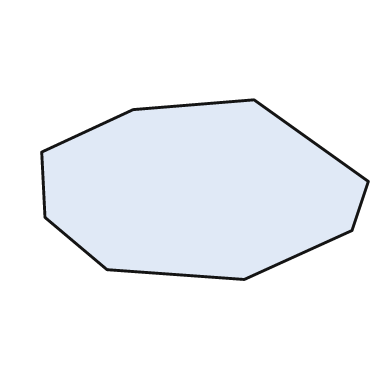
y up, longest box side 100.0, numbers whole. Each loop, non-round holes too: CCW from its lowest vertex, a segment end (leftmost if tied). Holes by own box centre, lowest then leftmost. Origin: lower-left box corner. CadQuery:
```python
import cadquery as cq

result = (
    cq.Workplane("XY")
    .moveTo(62.0, 0.0)
    .lineTo(95.0, 15.0)
    .lineTo(100.0, 30.0)
    .lineTo(65.0, 55.0)
    .lineTo(28.0, 52.0)
    .lineTo(0.0, 39.0)
    .lineTo(1.0, 19.0)
    .lineTo(20.0, 3.0)
    .close()
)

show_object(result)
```